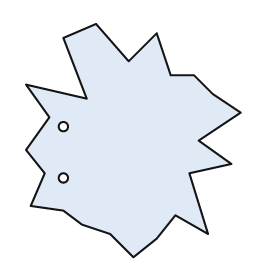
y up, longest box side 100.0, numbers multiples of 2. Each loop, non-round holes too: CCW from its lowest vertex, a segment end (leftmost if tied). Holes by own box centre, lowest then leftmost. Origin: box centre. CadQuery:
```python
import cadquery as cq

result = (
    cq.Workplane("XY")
    .moveTo(0.0, -50.0)
    .lineTo(10.0, -42.0)
    .lineTo(18.0, -32.0)
    .lineTo(32.0, -40.0)
    .lineTo(24.0, -14.0)
    .lineTo(42.0, -10.0)
    .lineTo(28.0, 0.0)
    .lineTo(46.0, 12.0)
    .lineTo(34.0, 20.0)
    .lineTo(26.0, 28.0)
    .lineTo(16.0, 28.0)
    .lineTo(10.0, 46.0)
    .lineTo(-2.0, 34.0)
    .lineTo(-16.0, 50.0)
    .lineTo(-30.0, 44.0)
    .lineTo(-20.0, 18.0)
    .lineTo(-46.0, 24.0)
    .lineTo(-36.0, 10.0)
    .lineTo(-46.0, -4.0)
    .lineTo(-38.0, -14.0)
    .lineTo(-44.0, -28.0)
    .lineTo(-30.0, -30.0)
    .lineTo(-22.0, -36.0)
    .lineTo(-10.0, -40.0)
    .close()
    .moveTo(-30.0, -16.0)
    .circle(2.0)
    .moveTo(-30.0, 6.0)
    .circle(2.0)
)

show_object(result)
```